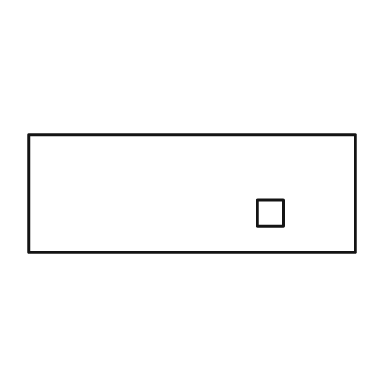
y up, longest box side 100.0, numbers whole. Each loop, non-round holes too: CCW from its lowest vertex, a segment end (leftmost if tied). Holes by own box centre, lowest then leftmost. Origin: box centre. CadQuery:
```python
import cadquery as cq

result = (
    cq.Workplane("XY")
    .moveTo(-50.0, -18.0)
    .lineTo(50.0, -18.0)
    .lineTo(50.0, 18.0)
    .lineTo(-50.0, 18.0)
    .close()
    .moveTo(20.0, -10.0)
    .lineTo(28.0, -10.0)
    .lineTo(28.0, -2.0)
    .lineTo(20.0, -2.0)
    .close()
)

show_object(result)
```